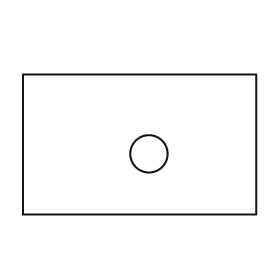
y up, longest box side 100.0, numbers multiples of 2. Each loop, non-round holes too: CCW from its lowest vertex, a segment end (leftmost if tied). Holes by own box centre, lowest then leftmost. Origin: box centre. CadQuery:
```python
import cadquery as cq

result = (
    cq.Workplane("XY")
    .moveTo(-50.0, -30.0)
    .lineTo(50.0, -30.0)
    .lineTo(50.0, 30.0)
    .lineTo(-50.0, 30.0)
    .close()
    .moveTo(4.0, -4.0)
    .circle(8.0)
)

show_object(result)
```